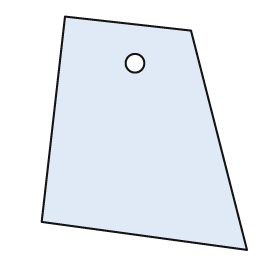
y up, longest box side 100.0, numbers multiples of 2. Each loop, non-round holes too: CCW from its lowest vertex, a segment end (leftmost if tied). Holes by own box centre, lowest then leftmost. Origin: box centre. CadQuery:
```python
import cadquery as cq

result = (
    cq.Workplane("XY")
    .moveTo(44.0, -50.0)
    .lineTo(20.0, 44.0)
    .lineTo(-34.0, 50.0)
    .lineTo(-44.0, -38.0)
    .close()
    .moveTo(-4.0, 30.0)
    .circle(4.0)
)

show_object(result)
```